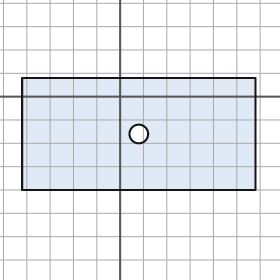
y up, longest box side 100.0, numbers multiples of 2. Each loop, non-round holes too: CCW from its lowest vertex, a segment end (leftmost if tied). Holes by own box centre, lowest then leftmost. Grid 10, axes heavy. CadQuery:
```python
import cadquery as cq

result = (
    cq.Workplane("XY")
    .moveTo(-42.0, -40.0)
    .lineTo(58.0, -40.0)
    .lineTo(58.0, 8.0)
    .lineTo(-42.0, 8.0)
    .close()
    .moveTo(8.0, -16.0)
    .circle(4.0)
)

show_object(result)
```